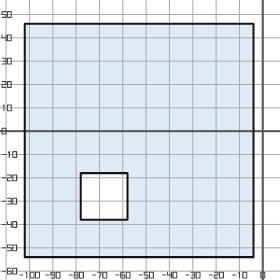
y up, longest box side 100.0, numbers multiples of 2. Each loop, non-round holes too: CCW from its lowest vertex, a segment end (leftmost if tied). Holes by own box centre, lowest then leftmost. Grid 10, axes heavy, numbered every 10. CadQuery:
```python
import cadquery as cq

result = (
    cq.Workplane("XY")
    .moveTo(-102.0, -54.0)
    .lineTo(-4.0, -54.0)
    .lineTo(-4.0, 46.0)
    .lineTo(-102.0, 46.0)
    .close()
    .moveTo(-78.0, -38.0)
    .lineTo(-58.0, -38.0)
    .lineTo(-58.0, -18.0)
    .lineTo(-78.0, -18.0)
    .close()
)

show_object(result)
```